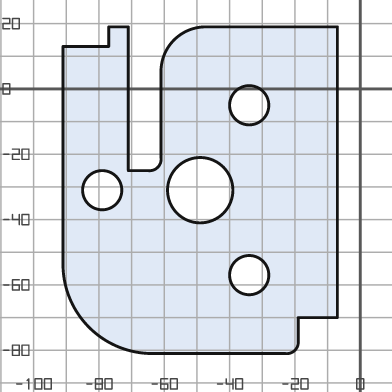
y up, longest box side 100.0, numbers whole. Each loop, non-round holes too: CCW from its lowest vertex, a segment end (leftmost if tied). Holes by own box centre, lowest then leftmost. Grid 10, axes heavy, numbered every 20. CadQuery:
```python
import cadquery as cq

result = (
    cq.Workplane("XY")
    .moveTo(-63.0, -81.0)
    .lineTo(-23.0, -81.0)
    .threePointArc((-20.0, -80.0), (-19.0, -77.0))
    .lineTo(-19.0, -70.0)
    .lineTo(-7.0, -70.0)
    .lineTo(-7.0, 19.0)
    .lineTo(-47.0, 19.0)
    .threePointArc((-57.0, 15.0), (-61.0, 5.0))
    .lineTo(-61.0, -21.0)
    .threePointArc((-62.0, -24.0), (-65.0, -25.0))
    .lineTo(-71.0, -25.0)
    .lineTo(-71.0, 19.0)
    .lineTo(-77.0, 19.0)
    .lineTo(-77.0, 13.0)
    .lineTo(-91.0, 13.0)
    .lineTo(-91.0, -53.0)
    .threePointArc((-83.0, -73.0), (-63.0, -81.0))
    .close()
    .moveTo(-34.0, -57.0)
    .circle(6.0)
    .moveTo(-79.0, -31.0)
    .circle(6.0)
    .moveTo(-49.0, -31.0)
    .circle(10.0)
    .moveTo(-34.0, -5.0)
    .circle(6.0)
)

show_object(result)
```